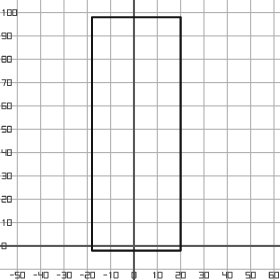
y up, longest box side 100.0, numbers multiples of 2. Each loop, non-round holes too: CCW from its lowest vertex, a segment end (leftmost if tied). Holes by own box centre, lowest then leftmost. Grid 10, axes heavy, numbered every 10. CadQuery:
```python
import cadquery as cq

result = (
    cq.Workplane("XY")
    .moveTo(-18.0, -2.0)
    .lineTo(20.0, -2.0)
    .lineTo(20.0, 98.0)
    .lineTo(-18.0, 98.0)
    .close()
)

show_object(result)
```